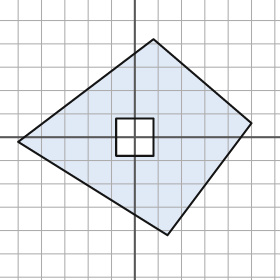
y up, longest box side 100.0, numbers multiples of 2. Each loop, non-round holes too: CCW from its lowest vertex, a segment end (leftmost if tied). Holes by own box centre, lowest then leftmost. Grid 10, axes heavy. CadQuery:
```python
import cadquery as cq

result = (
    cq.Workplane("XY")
    .moveTo(14.0, -42.0)
    .lineTo(50.0, 6.0)
    .lineTo(8.0, 42.0)
    .lineTo(-50.0, -2.0)
    .close()
    .moveTo(-8.0, -8.0)
    .lineTo(8.0, -8.0)
    .lineTo(8.0, 8.0)
    .lineTo(-8.0, 8.0)
    .close()
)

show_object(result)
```